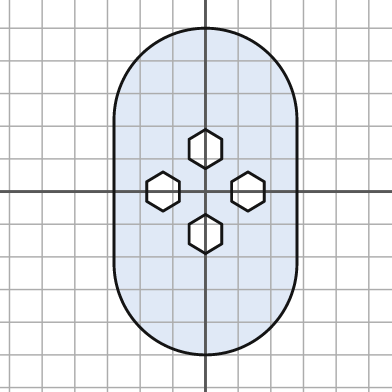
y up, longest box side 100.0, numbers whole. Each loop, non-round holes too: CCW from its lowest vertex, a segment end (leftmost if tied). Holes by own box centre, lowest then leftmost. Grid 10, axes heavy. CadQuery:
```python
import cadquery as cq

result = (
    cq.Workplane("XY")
    .moveTo(-28.0, -22.0)
    .threePointArc((0.0, -50.0), (28.0, -22.0))
    .lineTo(28.0, 22.0)
    .threePointArc((0.0, 50.0), (-28.0, 22.0))
    .close()
    .moveTo(0.0, -19.0)
    .lineTo(5.0, -16.0)
    .lineTo(5.0, -10.0)
    .lineTo(0.0, -7.0)
    .lineTo(-5.0, -10.0)
    .lineTo(-5.0, -16.0)
    .close()
    .moveTo(-13.0, -6.0)
    .lineTo(-8.0, -3.0)
    .lineTo(-8.0, 3.0)
    .lineTo(-13.0, 6.0)
    .lineTo(-18.0, 3.0)
    .lineTo(-18.0, -3.0)
    .close()
    .moveTo(13.0, -6.0)
    .lineTo(18.0, -3.0)
    .lineTo(18.0, 3.0)
    .lineTo(13.0, 6.0)
    .lineTo(8.0, 3.0)
    .lineTo(8.0, -3.0)
    .close()
    .moveTo(0.0, 7.0)
    .lineTo(5.0, 10.0)
    .lineTo(5.0, 16.0)
    .lineTo(0.0, 19.0)
    .lineTo(-5.0, 16.0)
    .lineTo(-5.0, 10.0)
    .close()
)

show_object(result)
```